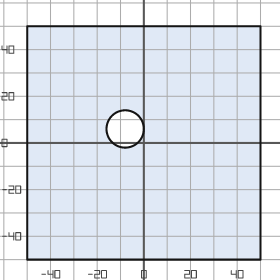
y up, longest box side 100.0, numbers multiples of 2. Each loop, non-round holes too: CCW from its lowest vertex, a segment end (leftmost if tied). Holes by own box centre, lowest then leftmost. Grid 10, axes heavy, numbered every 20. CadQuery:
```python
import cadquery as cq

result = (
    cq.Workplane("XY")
    .moveTo(-50.0, -50.0)
    .lineTo(50.0, -50.0)
    .lineTo(50.0, 50.0)
    .lineTo(-50.0, 50.0)
    .close()
    .moveTo(-8.0, 6.0)
    .circle(8.0)
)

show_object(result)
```